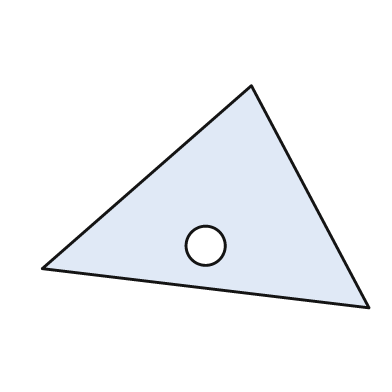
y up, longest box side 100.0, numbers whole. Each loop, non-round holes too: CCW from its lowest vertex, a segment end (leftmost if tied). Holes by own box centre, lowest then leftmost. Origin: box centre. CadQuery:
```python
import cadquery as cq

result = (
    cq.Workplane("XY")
    .moveTo(50.0, -34.0)
    .lineTo(14.0, 34.0)
    .lineTo(-50.0, -22.0)
    .close()
    .moveTo(0.0, -15.0)
    .circle(6.0)
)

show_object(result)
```